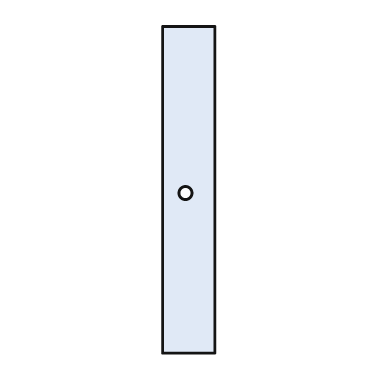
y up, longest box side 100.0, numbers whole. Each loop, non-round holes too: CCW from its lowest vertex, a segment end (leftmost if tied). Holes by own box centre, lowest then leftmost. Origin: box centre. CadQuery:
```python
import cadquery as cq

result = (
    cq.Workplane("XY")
    .moveTo(-8.0, -50.0)
    .lineTo(8.0, -50.0)
    .lineTo(8.0, 50.0)
    .lineTo(-8.0, 50.0)
    .close()
    .moveTo(-1.0, -1.0)
    .circle(2.0)
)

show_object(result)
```